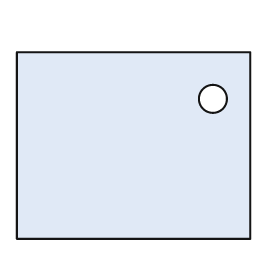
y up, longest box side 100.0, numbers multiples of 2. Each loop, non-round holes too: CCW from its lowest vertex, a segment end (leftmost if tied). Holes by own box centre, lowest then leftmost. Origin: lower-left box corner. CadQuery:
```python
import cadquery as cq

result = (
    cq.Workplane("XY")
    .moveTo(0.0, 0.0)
    .lineTo(100.0, 0.0)
    .lineTo(100.0, 80.0)
    .lineTo(0.0, 80.0)
    .close()
    .moveTo(84.0, 60.0)
    .circle(6.0)
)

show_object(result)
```